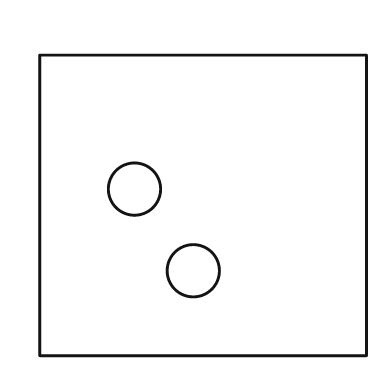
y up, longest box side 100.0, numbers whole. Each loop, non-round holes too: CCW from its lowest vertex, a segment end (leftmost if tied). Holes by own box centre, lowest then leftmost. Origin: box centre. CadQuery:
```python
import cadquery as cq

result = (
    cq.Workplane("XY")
    .moveTo(-50.0, -46.0)
    .lineTo(50.0, -46.0)
    .lineTo(50.0, 46.0)
    .lineTo(-50.0, 46.0)
    .close()
    .moveTo(-3.0, -20.0)
    .circle(8.0)
    .moveTo(-21.0, 5.0)
    .circle(8.0)
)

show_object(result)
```